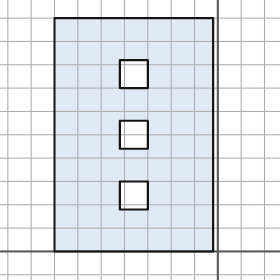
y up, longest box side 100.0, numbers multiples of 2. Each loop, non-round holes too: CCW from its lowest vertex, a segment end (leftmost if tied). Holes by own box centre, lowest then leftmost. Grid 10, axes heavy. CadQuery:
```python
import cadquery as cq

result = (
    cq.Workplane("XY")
    .moveTo(-70.0, 0.0)
    .lineTo(-2.0, 0.0)
    .lineTo(-2.0, 100.0)
    .lineTo(-70.0, 100.0)
    .close()
    .moveTo(-42.0, 18.0)
    .lineTo(-30.0, 18.0)
    .lineTo(-30.0, 30.0)
    .lineTo(-42.0, 30.0)
    .close()
    .moveTo(-42.0, 44.0)
    .lineTo(-30.0, 44.0)
    .lineTo(-30.0, 56.0)
    .lineTo(-42.0, 56.0)
    .close()
    .moveTo(-42.0, 70.0)
    .lineTo(-30.0, 70.0)
    .lineTo(-30.0, 82.0)
    .lineTo(-42.0, 82.0)
    .close()
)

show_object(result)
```